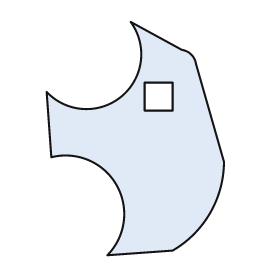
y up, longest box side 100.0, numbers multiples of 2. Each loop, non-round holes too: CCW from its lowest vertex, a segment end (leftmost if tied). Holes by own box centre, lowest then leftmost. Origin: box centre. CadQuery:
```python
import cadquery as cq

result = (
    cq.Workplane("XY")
    .moveTo(-12.0, -50.0)
    .lineTo(16.0, -48.0)
    .threePointArc((32.0, -32.0), (38.0, -10.0))
    .lineTo(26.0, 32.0)
    .threePointArc((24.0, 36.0), (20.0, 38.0))
    .lineTo(-2.0, 50.0)
    .threePointArc((-6.0, 18.0), (-38.0, 20.0))
    .lineTo(-36.0, -8.0)
    .threePointArc((-8.0, -20.0), (-12.0, -50.0))
    .close()
    .moveTo(4.0, 12.0)
    .lineTo(16.0, 12.0)
    .lineTo(16.0, 24.0)
    .lineTo(4.0, 24.0)
    .close()
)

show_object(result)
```